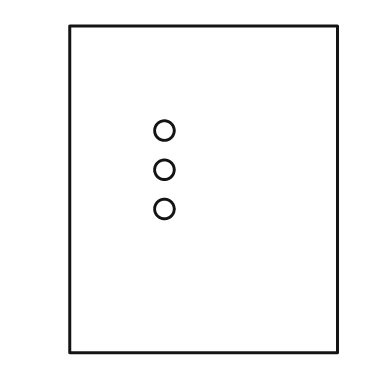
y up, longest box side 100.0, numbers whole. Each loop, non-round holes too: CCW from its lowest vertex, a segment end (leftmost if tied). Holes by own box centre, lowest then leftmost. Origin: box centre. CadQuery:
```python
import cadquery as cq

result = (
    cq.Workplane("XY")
    .moveTo(-41.0, -50.0)
    .lineTo(41.0, -50.0)
    .lineTo(41.0, 50.0)
    .lineTo(-41.0, 50.0)
    .close()
    .moveTo(-12.0, -6.0)
    .circle(3.0)
    .moveTo(-12.0, 6.0)
    .circle(3.0)
    .moveTo(-12.0, 18.0)
    .circle(3.0)
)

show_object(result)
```